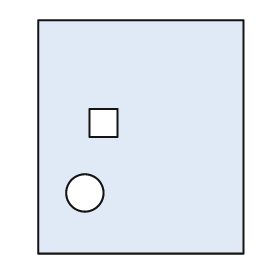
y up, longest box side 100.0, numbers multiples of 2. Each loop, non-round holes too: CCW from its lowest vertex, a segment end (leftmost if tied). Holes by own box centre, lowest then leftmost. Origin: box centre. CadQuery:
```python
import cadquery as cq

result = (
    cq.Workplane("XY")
    .moveTo(-44.0, -50.0)
    .lineTo(44.0, -50.0)
    .lineTo(44.0, 50.0)
    .lineTo(-44.0, 50.0)
    .close()
    .moveTo(-24.0, -24.0)
    .circle(8.0)
    .moveTo(-22.0, 0.0)
    .lineTo(-10.0, 0.0)
    .lineTo(-10.0, 12.0)
    .lineTo(-22.0, 12.0)
    .close()
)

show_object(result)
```